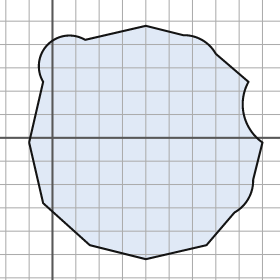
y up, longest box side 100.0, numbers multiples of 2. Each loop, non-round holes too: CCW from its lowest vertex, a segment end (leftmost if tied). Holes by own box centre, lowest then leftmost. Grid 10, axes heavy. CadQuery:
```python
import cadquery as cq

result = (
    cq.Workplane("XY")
    .moveTo(40.0, -52.0)
    .lineTo(66.0, -46.0)
    .lineTo(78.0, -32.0)
    .threePointArc((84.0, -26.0), (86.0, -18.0))
    .lineTo(90.0, -2.0)
    .threePointArc((82.0, 10.0), (84.0, 24.0))
    .lineTo(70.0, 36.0)
    .threePointArc((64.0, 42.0), (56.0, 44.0))
    .lineTo(40.0, 48.0)
    .lineTo(14.0, 42.0)
    .threePointArc((-2.0, 40.0), (-4.0, 24.0))
    .lineTo(-10.0, -2.0)
    .lineTo(-4.0, -28.0)
    .lineTo(16.0, -46.0)
    .close()
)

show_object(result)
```